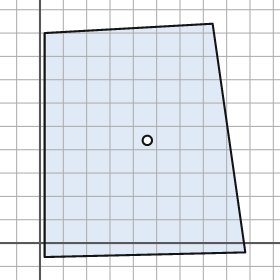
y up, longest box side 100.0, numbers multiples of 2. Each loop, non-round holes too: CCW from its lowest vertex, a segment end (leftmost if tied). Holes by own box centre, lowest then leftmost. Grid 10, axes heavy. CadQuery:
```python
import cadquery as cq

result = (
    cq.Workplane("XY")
    .moveTo(2.0, -6.0)
    .lineTo(88.0, -4.0)
    .lineTo(74.0, 94.0)
    .lineTo(2.0, 90.0)
    .close()
    .moveTo(46.0, 44.0)
    .circle(2.0)
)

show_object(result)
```